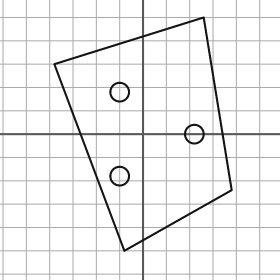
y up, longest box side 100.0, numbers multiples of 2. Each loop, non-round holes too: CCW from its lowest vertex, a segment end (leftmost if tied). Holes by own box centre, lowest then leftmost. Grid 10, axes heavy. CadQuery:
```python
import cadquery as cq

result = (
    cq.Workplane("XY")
    .moveTo(-8.0, -50.0)
    .lineTo(38.0, -24.0)
    .lineTo(26.0, 50.0)
    .lineTo(-38.0, 30.0)
    .close()
    .moveTo(-10.0, -18.0)
    .circle(4.0)
    .moveTo(22.0, 0.0)
    .circle(4.0)
    .moveTo(-10.0, 18.0)
    .circle(4.0)
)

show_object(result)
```